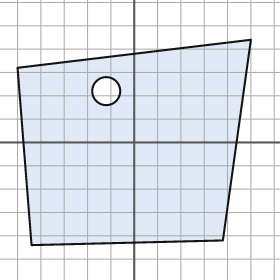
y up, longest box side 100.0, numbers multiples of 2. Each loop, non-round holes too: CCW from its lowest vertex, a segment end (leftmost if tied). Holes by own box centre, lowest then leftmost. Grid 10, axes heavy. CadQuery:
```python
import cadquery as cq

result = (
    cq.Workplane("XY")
    .moveTo(-44.0, -44.0)
    .lineTo(38.0, -42.0)
    .lineTo(50.0, 44.0)
    .lineTo(-50.0, 32.0)
    .close()
    .moveTo(-12.0, 22.0)
    .circle(6.0)
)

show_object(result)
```